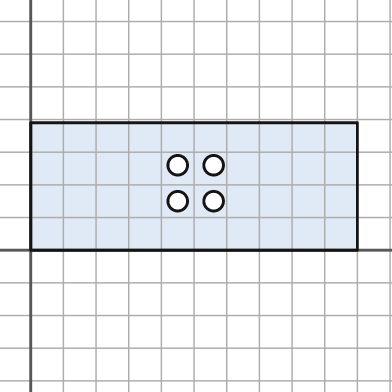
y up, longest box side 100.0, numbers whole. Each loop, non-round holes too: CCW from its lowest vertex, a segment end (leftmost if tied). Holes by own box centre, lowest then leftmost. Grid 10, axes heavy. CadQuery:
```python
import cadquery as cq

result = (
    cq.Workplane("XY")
    .moveTo(0.0, 0.0)
    .lineTo(100.0, 0.0)
    .lineTo(100.0, 39.0)
    .lineTo(0.0, 39.0)
    .close()
    .moveTo(45.0, 15.0)
    .circle(3.0)
    .moveTo(56.0, 15.0)
    .circle(3.0)
    .moveTo(45.0, 26.0)
    .circle(3.0)
    .moveTo(56.0, 26.0)
    .circle(3.0)
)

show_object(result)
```